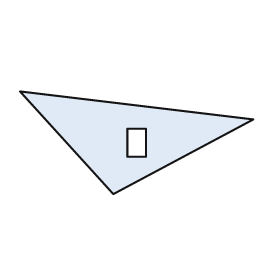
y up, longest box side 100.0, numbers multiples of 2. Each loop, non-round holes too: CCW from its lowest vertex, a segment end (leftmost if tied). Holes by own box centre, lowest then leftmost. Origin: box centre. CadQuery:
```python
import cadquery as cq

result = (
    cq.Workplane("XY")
    .moveTo(-10.0, -22.0)
    .lineTo(50.0, 10.0)
    .lineTo(-50.0, 22.0)
    .close()
    .moveTo(-4.0, -6.0)
    .lineTo(4.0, -6.0)
    .lineTo(4.0, 6.0)
    .lineTo(-4.0, 6.0)
    .close()
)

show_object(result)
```